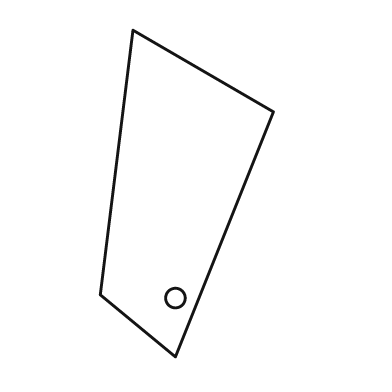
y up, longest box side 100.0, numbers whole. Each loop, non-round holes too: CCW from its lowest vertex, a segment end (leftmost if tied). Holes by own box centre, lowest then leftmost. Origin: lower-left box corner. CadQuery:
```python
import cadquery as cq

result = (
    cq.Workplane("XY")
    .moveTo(23.0, 0.0)
    .lineTo(53.0, 75.0)
    .lineTo(10.0, 100.0)
    .lineTo(0.0, 19.0)
    .close()
    .moveTo(23.0, 18.0)
    .circle(3.0)
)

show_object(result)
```